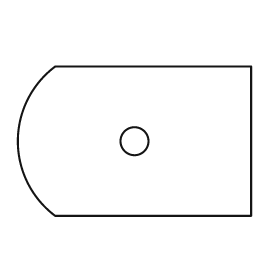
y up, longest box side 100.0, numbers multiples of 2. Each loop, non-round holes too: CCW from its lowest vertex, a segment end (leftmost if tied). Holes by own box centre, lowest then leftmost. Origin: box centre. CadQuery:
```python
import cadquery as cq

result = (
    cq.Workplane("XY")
    .moveTo(-34.0, -32.0)
    .lineTo(50.0, -32.0)
    .lineTo(50.0, 32.0)
    .lineTo(-34.0, 32.0)
    .threePointArc((-50.0, 0.0), (-34.0, -32.0))
    .close()
    .moveTo(0.0, 0.0)
    .circle(6.0)
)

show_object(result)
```